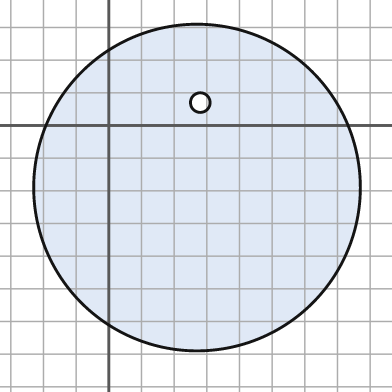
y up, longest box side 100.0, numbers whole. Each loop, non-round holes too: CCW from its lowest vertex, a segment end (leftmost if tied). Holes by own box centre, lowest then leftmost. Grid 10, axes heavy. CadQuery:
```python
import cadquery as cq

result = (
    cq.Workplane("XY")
    .moveTo(27.0, -19.0)
    .circle(50.0)
    .moveTo(28.0, 7.0)
    .circle(3.0)
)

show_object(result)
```